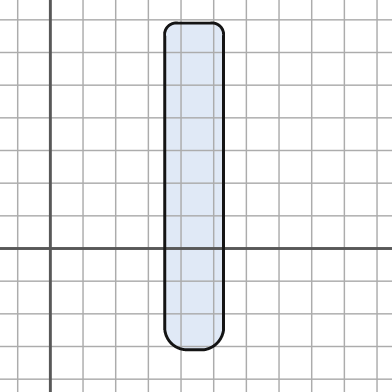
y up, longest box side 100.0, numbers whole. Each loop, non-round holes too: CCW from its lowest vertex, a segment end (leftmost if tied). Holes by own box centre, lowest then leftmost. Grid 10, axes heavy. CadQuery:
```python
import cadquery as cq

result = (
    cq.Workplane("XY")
    .moveTo(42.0, -31.0)
    .lineTo(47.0, -31.0)
    .threePointArc((51.0, -29.0), (53.0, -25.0))
    .lineTo(53.0, 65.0)
    .threePointArc((52.0, 68.0), (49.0, 69.0))
    .lineTo(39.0, 69.0)
    .threePointArc((36.0, 68.0), (35.0, 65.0))
    .lineTo(35.0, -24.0)
    .threePointArc((37.0, -29.0), (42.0, -31.0))
    .close()
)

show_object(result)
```